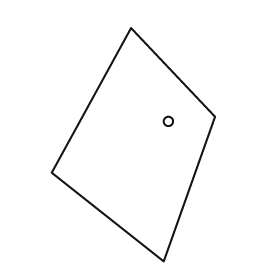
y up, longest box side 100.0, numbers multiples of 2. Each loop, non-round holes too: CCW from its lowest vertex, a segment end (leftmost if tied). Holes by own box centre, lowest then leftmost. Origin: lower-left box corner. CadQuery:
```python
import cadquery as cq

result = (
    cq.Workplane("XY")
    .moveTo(48.0, 0.0)
    .lineTo(70.0, 62.0)
    .lineTo(34.0, 100.0)
    .lineTo(0.0, 38.0)
    .close()
    .moveTo(50.0, 60.0)
    .circle(2.0)
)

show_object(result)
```